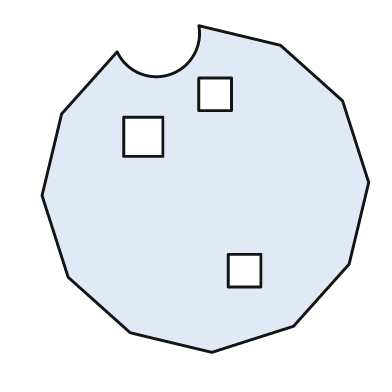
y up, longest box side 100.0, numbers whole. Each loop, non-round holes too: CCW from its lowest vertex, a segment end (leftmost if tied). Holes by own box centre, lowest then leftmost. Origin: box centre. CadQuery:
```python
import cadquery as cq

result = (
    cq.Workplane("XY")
    .moveTo(2.0, -50.0)
    .lineTo(27.0, -42.0)
    .lineTo(44.0, -23.0)
    .lineTo(50.0, 2.0)
    .lineTo(42.0, 27.0)
    .lineTo(23.0, 44.0)
    .lineTo(-2.0, 50.0)
    .threePointArc((-11.0, 35.0), (-27.0, 42.0))
    .lineTo(-44.0, 23.0)
    .lineTo(-50.0, -2.0)
    .lineTo(-42.0, -27.0)
    .lineTo(-23.0, -44.0)
    .close()
    .moveTo(7.0, -30.0)
    .lineTo(17.0, -30.0)
    .lineTo(17.0, -20.0)
    .lineTo(7.0, -20.0)
    .close()
    .moveTo(-25.0, 10.0)
    .lineTo(-13.0, 10.0)
    .lineTo(-13.0, 22.0)
    .lineTo(-25.0, 22.0)
    .close()
    .moveTo(-2.0, 24.0)
    .lineTo(8.0, 24.0)
    .lineTo(8.0, 34.0)
    .lineTo(-2.0, 34.0)
    .close()
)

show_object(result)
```